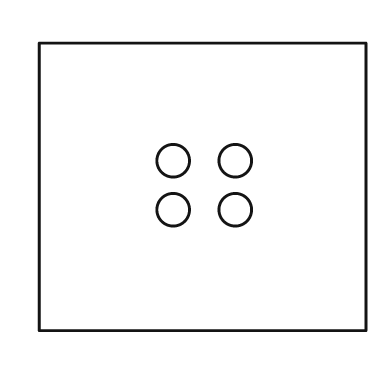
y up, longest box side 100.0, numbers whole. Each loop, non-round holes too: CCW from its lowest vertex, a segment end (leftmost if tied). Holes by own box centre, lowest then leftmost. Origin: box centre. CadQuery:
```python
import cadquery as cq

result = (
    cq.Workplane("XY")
    .moveTo(-50.0, -44.0)
    .lineTo(50.0, -44.0)
    .lineTo(50.0, 44.0)
    .lineTo(-50.0, 44.0)
    .close()
    .moveTo(-9.0, -7.0)
    .circle(5.0)
    .moveTo(10.0, -7.0)
    .circle(5.0)
    .moveTo(-9.0, 8.0)
    .circle(5.0)
    .moveTo(10.0, 8.0)
    .circle(5.0)
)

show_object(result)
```